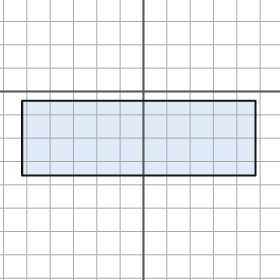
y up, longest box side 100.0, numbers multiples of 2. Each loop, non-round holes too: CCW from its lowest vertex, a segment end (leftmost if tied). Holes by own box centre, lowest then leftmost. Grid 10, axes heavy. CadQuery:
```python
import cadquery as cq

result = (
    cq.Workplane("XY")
    .moveTo(-52.0, -36.0)
    .lineTo(48.0, -36.0)
    .lineTo(48.0, -4.0)
    .lineTo(-52.0, -4.0)
    .close()
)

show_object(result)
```